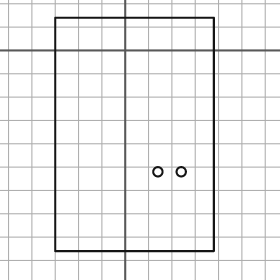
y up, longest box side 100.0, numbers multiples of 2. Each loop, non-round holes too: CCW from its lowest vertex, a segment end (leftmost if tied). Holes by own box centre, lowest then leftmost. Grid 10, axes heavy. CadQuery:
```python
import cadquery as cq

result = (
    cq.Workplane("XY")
    .moveTo(-30.0, -86.0)
    .lineTo(38.0, -86.0)
    .lineTo(38.0, 14.0)
    .lineTo(-30.0, 14.0)
    .close()
    .moveTo(14.0, -52.0)
    .circle(2.0)
    .moveTo(24.0, -52.0)
    .circle(2.0)
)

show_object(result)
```